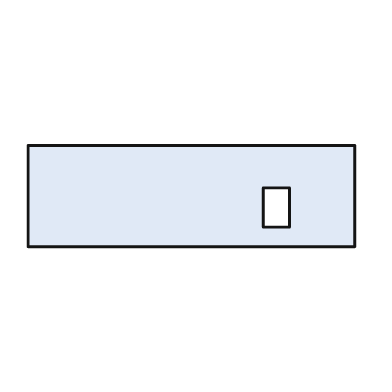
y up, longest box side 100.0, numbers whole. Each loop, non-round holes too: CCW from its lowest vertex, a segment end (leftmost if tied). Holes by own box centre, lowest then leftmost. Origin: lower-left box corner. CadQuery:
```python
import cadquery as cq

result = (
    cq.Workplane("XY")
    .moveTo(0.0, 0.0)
    .lineTo(100.0, 0.0)
    .lineTo(100.0, 31.0)
    .lineTo(0.0, 31.0)
    .close()
    .moveTo(72.0, 6.0)
    .lineTo(80.0, 6.0)
    .lineTo(80.0, 18.0)
    .lineTo(72.0, 18.0)
    .close()
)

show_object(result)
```